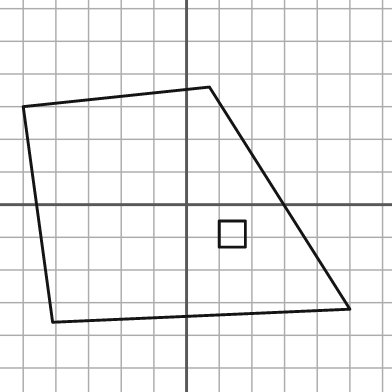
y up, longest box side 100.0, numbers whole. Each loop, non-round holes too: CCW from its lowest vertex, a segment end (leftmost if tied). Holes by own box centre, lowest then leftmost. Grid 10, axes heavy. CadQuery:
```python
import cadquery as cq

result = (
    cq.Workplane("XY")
    .moveTo(-41.0, -36.0)
    .lineTo(50.0, -32.0)
    .lineTo(7.0, 36.0)
    .lineTo(-50.0, 30.0)
    .close()
    .moveTo(10.0, -13.0)
    .lineTo(18.0, -13.0)
    .lineTo(18.0, -5.0)
    .lineTo(10.0, -5.0)
    .close()
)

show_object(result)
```